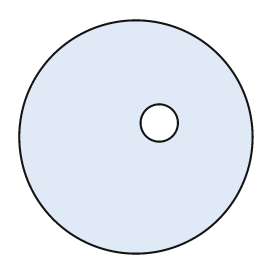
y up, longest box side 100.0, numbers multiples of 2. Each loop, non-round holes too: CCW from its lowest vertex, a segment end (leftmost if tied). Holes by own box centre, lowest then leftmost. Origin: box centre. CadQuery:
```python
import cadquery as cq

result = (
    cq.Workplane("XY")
    .moveTo(0.0, 0.0)
    .circle(50.0)
    .moveTo(10.0, 6.0)
    .circle(8.0)
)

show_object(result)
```